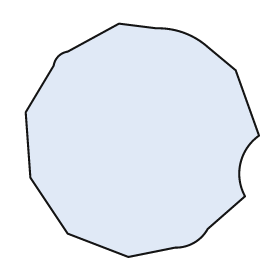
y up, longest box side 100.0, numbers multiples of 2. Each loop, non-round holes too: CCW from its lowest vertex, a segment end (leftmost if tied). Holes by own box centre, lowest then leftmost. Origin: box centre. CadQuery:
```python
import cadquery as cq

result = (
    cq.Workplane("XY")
    .moveTo(-6.0, -50.0)
    .lineTo(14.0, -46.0)
    .threePointArc((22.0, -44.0), (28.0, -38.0))
    .lineTo(44.0, -24.0)
    .threePointArc((42.0, -10.0), (50.0, 2.0))
    .lineTo(40.0, 30.0)
    .lineTo(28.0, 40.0)
    .threePointArc((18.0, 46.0), (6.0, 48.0))
    .lineTo(-10.0, 50.0)
    .lineTo(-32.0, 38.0)
    .threePointArc((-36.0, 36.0), (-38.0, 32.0))
    .lineTo(-50.0, 12.0)
    .lineTo(-48.0, -16.0)
    .lineTo(-32.0, -40.0)
    .close()
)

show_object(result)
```